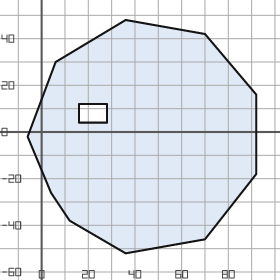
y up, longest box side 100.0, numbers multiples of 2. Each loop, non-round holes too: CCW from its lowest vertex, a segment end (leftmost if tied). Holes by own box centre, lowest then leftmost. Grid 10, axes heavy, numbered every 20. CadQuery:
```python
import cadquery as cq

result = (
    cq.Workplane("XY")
    .moveTo(36.0, -52.0)
    .lineTo(70.0, -46.0)
    .lineTo(92.0, -18.0)
    .lineTo(92.0, 16.0)
    .lineTo(70.0, 42.0)
    .lineTo(36.0, 48.0)
    .lineTo(6.0, 30.0)
    .lineTo(-6.0, -2.0)
    .lineTo(4.0, -26.0)
    .lineTo(12.0, -38.0)
    .close()
    .moveTo(16.0, 4.0)
    .lineTo(28.0, 4.0)
    .lineTo(28.0, 12.0)
    .lineTo(16.0, 12.0)
    .close()
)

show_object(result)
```